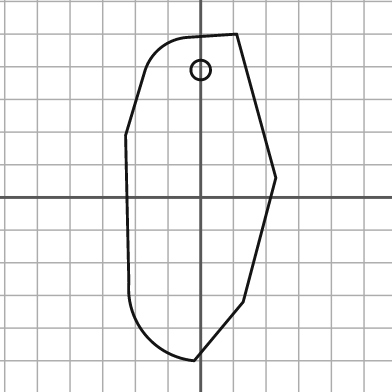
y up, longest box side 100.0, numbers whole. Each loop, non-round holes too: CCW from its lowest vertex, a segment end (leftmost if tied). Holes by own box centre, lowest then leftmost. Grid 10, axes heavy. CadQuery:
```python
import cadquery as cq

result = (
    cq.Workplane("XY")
    .moveTo(-2.0, -50.0)
    .lineTo(13.0, -32.0)
    .lineTo(23.0, 6.0)
    .lineTo(11.0, 50.0)
    .lineTo(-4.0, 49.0)
    .threePointArc((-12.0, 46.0), (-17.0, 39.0))
    .lineTo(-23.0, 19.0)
    .lineTo(-22.0, -26.0)
    .threePointArc((-17.0, -42.0), (-2.0, -50.0))
    .close()
    .moveTo(0.0, 39.0)
    .circle(3.0)
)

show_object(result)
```